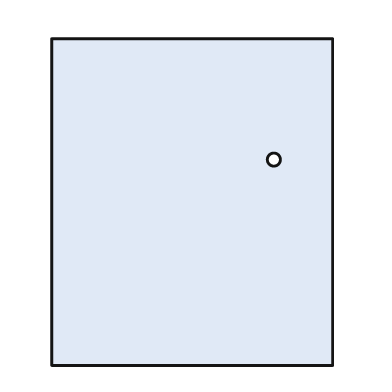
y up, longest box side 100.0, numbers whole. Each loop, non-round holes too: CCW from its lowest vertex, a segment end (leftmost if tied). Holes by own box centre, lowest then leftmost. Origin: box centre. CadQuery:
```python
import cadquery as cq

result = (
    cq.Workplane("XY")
    .moveTo(-43.0, -50.0)
    .lineTo(43.0, -50.0)
    .lineTo(43.0, 50.0)
    .lineTo(-43.0, 50.0)
    .close()
    .moveTo(25.0, 13.0)
    .circle(2.0)
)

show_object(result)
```